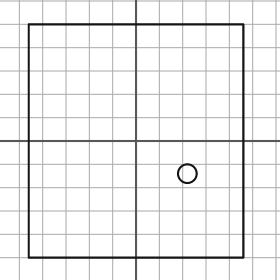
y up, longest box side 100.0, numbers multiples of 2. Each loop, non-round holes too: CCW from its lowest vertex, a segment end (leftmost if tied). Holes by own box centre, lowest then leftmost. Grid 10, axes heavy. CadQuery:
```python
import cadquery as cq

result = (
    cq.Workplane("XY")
    .moveTo(-46.0, -50.0)
    .lineTo(46.0, -50.0)
    .lineTo(46.0, 50.0)
    .lineTo(-46.0, 50.0)
    .close()
    .moveTo(22.0, -14.0)
    .circle(4.0)
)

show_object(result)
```